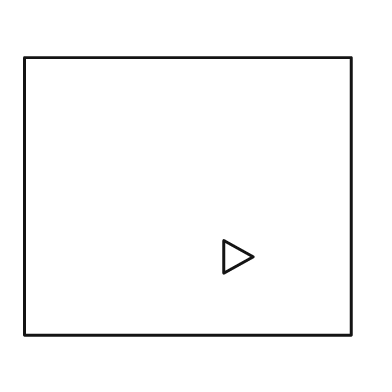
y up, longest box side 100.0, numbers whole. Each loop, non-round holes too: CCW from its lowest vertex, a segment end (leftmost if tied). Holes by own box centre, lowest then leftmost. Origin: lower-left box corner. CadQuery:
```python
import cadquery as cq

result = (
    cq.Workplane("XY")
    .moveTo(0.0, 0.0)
    .lineTo(100.0, 0.0)
    .lineTo(100.0, 85.0)
    .lineTo(0.0, 85.0)
    .close()
    .moveTo(61.0, 19.0)
    .lineTo(70.0, 24.0)
    .lineTo(61.0, 29.0)
    .close()
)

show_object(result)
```